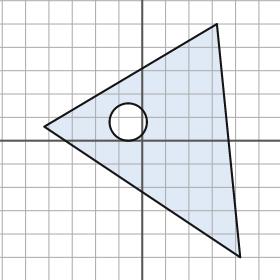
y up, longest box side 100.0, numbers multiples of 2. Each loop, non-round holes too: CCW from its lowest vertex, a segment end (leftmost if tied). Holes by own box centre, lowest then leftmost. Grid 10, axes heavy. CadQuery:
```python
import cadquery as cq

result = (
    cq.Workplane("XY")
    .moveTo(42.0, -50.0)
    .lineTo(32.0, 50.0)
    .lineTo(-42.0, 6.0)
    .close()
    .moveTo(-6.0, 8.0)
    .circle(8.0)
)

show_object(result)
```